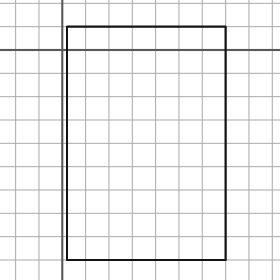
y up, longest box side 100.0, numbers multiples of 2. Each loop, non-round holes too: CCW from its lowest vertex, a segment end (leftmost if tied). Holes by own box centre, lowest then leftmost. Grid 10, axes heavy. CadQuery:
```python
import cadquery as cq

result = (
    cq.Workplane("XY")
    .moveTo(2.0, -90.0)
    .lineTo(70.0, -90.0)
    .lineTo(70.0, 10.0)
    .lineTo(2.0, 10.0)
    .close()
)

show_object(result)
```